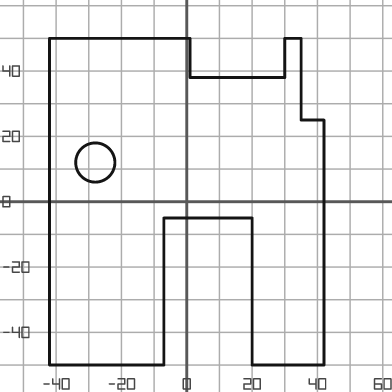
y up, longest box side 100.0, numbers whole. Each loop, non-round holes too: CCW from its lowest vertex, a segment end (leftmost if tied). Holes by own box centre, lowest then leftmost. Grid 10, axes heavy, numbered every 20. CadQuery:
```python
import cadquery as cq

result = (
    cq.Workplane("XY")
    .moveTo(-42.0, -50.0)
    .lineTo(-7.0, -50.0)
    .lineTo(-7.0, -5.0)
    .lineTo(20.0, -5.0)
    .lineTo(20.0, -50.0)
    .lineTo(42.0, -50.0)
    .lineTo(42.0, 25.0)
    .lineTo(35.0, 25.0)
    .lineTo(35.0, 50.0)
    .lineTo(30.0, 50.0)
    .lineTo(30.0, 38.0)
    .lineTo(1.0, 38.0)
    .lineTo(1.0, 50.0)
    .lineTo(-42.0, 50.0)
    .close()
    .moveTo(-28.0, 12.0)
    .circle(6.0)
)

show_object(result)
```